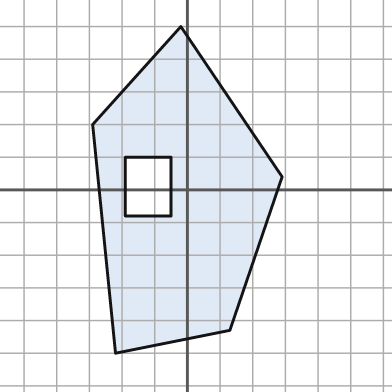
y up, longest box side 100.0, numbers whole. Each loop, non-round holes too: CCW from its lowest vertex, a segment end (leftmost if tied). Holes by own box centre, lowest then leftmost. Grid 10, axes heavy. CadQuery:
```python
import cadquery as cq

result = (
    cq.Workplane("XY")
    .moveTo(-22.0, -50.0)
    .lineTo(13.0, -43.0)
    .lineTo(29.0, 4.0)
    .lineTo(-2.0, 50.0)
    .lineTo(-29.0, 20.0)
    .close()
    .moveTo(-19.0, -8.0)
    .lineTo(-5.0, -8.0)
    .lineTo(-5.0, 10.0)
    .lineTo(-19.0, 10.0)
    .close()
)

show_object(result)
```